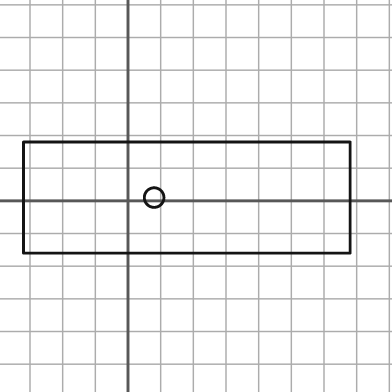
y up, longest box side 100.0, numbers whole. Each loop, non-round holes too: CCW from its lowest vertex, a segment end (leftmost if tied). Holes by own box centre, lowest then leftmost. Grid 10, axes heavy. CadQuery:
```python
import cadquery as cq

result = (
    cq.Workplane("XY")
    .moveTo(-32.0, -16.0)
    .lineTo(68.0, -16.0)
    .lineTo(68.0, 18.0)
    .lineTo(-32.0, 18.0)
    .close()
    .moveTo(8.0, 1.0)
    .circle(3.0)
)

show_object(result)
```